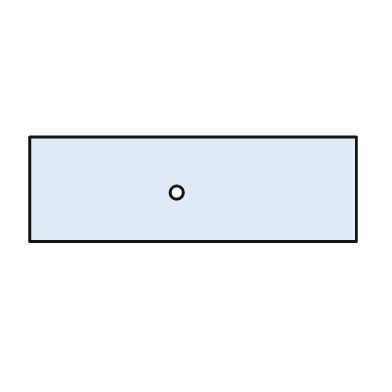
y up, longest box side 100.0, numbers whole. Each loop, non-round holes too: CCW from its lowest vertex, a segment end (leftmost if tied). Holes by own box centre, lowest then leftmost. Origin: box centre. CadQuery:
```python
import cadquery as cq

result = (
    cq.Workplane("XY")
    .moveTo(-50.0, -16.0)
    .lineTo(50.0, -16.0)
    .lineTo(50.0, 16.0)
    .lineTo(-50.0, 16.0)
    .close()
    .moveTo(-5.0, -1.0)
    .circle(2.0)
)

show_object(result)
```